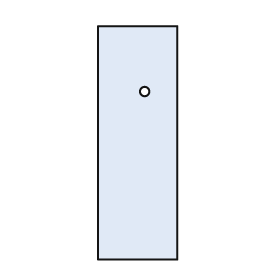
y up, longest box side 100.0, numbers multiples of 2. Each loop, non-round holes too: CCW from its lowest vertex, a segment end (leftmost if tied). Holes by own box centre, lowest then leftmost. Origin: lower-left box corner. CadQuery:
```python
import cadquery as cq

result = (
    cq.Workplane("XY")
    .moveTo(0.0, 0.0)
    .lineTo(34.0, 0.0)
    .lineTo(34.0, 100.0)
    .lineTo(0.0, 100.0)
    .close()
    .moveTo(20.0, 72.0)
    .circle(2.0)
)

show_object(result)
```